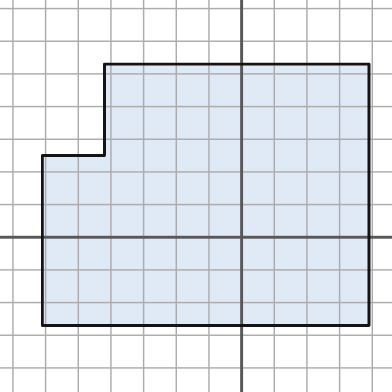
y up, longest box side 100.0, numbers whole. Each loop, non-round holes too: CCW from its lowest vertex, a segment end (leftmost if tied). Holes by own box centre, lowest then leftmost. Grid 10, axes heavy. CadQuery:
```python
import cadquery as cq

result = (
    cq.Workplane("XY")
    .moveTo(-61.0, -27.0)
    .lineTo(39.0, -27.0)
    .lineTo(39.0, 53.0)
    .lineTo(-42.0, 53.0)
    .lineTo(-42.0, 25.0)
    .lineTo(-61.0, 25.0)
    .close()
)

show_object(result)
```